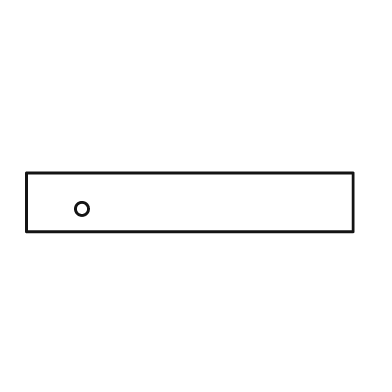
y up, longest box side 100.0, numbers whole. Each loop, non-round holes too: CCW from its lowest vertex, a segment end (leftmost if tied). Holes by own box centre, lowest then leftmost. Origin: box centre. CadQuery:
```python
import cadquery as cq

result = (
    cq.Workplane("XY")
    .moveTo(-50.0, -9.0)
    .lineTo(50.0, -9.0)
    .lineTo(50.0, 9.0)
    .lineTo(-50.0, 9.0)
    .close()
    .moveTo(-33.0, -2.0)
    .circle(2.0)
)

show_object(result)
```